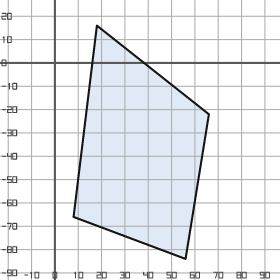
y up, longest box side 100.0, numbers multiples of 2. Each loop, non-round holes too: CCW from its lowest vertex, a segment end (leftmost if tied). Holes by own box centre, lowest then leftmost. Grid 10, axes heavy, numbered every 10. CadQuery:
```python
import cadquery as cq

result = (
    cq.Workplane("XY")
    .moveTo(56.0, -84.0)
    .lineTo(66.0, -22.0)
    .lineTo(18.0, 16.0)
    .lineTo(8.0, -66.0)
    .close()
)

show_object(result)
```